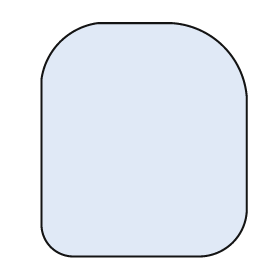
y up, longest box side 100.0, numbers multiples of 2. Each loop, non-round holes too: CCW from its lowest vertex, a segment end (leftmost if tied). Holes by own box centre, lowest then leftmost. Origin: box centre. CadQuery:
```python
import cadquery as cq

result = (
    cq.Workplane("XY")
    .moveTo(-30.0, -50.0)
    .lineTo(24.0, -50.0)
    .threePointArc((38.0, -44.0), (44.0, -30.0))
    .lineTo(44.0, 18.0)
    .threePointArc((34.0, 40.0), (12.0, 50.0))
    .lineTo(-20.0, 50.0)
    .threePointArc((-36.0, 42.0), (-44.0, 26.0))
    .lineTo(-44.0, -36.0)
    .threePointArc((-40.0, -46.0), (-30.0, -50.0))
    .close()
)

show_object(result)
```